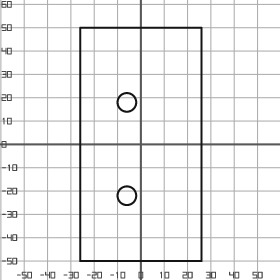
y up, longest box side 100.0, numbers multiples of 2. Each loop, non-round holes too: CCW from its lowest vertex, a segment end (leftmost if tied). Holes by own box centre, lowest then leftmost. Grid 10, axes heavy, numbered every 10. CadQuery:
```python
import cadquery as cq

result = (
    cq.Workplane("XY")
    .moveTo(-26.0, -50.0)
    .lineTo(26.0, -50.0)
    .lineTo(26.0, 50.0)
    .lineTo(-26.0, 50.0)
    .close()
    .moveTo(-6.0, -22.0)
    .circle(4.0)
    .moveTo(-6.0, 18.0)
    .circle(4.0)
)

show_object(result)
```